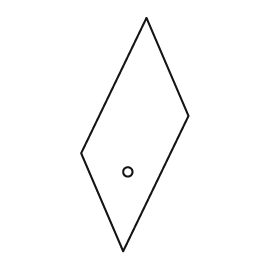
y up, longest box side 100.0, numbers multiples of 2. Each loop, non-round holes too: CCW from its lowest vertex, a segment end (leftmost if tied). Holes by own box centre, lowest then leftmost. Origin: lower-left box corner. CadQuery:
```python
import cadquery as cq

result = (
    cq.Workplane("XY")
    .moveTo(18.0, 0.0)
    .lineTo(46.0, 58.0)
    .lineTo(28.0, 100.0)
    .lineTo(0.0, 42.0)
    .close()
    .moveTo(20.0, 34.0)
    .circle(2.0)
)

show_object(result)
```